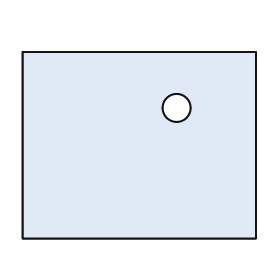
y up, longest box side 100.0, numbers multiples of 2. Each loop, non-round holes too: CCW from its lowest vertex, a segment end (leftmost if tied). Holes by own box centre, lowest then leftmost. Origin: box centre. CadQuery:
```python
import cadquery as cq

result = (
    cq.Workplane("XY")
    .moveTo(-50.0, -40.0)
    .lineTo(50.0, -40.0)
    .lineTo(50.0, 40.0)
    .lineTo(-50.0, 40.0)
    .close()
    .moveTo(16.0, 16.0)
    .circle(6.0)
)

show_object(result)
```